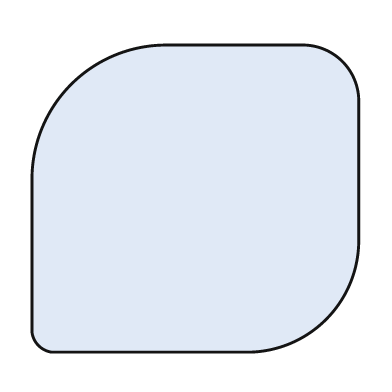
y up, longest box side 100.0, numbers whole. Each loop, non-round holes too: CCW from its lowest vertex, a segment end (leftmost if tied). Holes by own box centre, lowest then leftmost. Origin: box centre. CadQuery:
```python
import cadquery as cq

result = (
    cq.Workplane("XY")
    .moveTo(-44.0, -47.0)
    .lineTo(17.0, -47.0)
    .threePointArc((40.0, -37.0), (50.0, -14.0))
    .lineTo(50.0, 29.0)
    .threePointArc((45.0, 42.0), (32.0, 47.0))
    .lineTo(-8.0, 47.0)
    .threePointArc((-38.0, 35.0), (-50.0, 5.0))
    .lineTo(-50.0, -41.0)
    .threePointArc((-48.0, -45.0), (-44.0, -47.0))
    .close()
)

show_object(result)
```